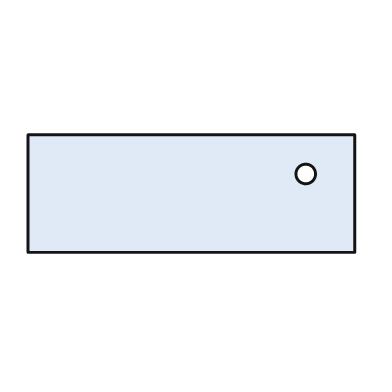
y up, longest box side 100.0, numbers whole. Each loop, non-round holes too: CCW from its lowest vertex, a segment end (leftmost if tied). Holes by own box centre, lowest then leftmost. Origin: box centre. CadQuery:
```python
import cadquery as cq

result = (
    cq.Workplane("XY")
    .moveTo(-50.0, -18.0)
    .lineTo(50.0, -18.0)
    .lineTo(50.0, 18.0)
    .lineTo(-50.0, 18.0)
    .close()
    .moveTo(35.0, 6.0)
    .circle(3.0)
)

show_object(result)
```